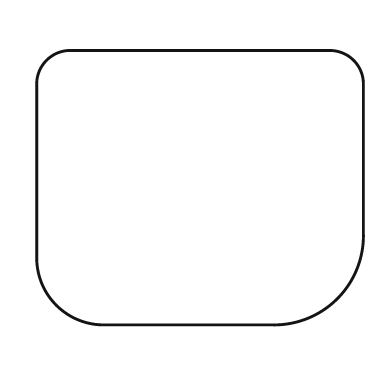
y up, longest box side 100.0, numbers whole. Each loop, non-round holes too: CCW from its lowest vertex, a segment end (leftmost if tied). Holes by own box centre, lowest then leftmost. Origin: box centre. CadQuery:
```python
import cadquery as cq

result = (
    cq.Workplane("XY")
    .moveTo(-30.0, -42.0)
    .lineTo(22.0, -42.0)
    .threePointArc((42.0, -34.0), (50.0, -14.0))
    .lineTo(50.0, 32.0)
    .threePointArc((47.0, 39.0), (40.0, 42.0))
    .lineTo(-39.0, 42.0)
    .threePointArc((-47.0, 39.0), (-50.0, 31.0))
    .lineTo(-50.0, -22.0)
    .threePointArc((-44.0, -36.0), (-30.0, -42.0))
    .close()
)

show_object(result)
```